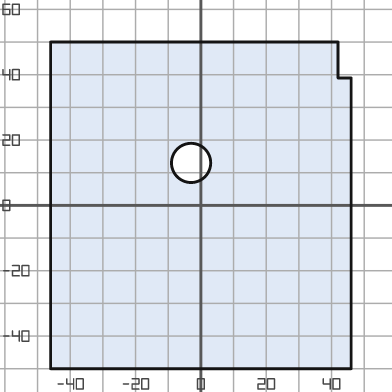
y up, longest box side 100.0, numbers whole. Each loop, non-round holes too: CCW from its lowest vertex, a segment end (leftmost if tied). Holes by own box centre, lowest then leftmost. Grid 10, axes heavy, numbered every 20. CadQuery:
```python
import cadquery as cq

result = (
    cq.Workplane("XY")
    .moveTo(-46.0, -50.0)
    .lineTo(46.0, -50.0)
    .lineTo(46.0, 39.0)
    .lineTo(42.0, 39.0)
    .lineTo(42.0, 50.0)
    .lineTo(-46.0, 50.0)
    .close()
    .moveTo(-3.0, 13.0)
    .circle(6.0)
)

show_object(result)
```